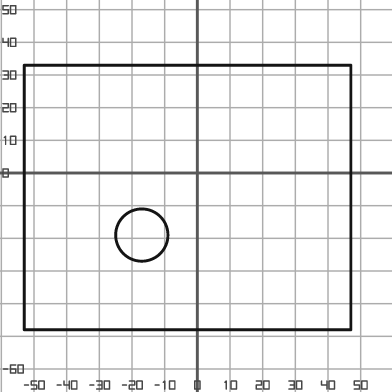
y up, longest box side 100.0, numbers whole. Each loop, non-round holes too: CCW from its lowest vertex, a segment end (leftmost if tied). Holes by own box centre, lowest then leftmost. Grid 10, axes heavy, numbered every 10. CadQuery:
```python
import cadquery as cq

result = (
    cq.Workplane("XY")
    .moveTo(-53.0, -48.0)
    .lineTo(47.0, -48.0)
    .lineTo(47.0, 33.0)
    .lineTo(-53.0, 33.0)
    .close()
    .moveTo(-17.0, -19.0)
    .circle(8.0)
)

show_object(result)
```